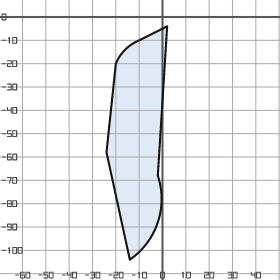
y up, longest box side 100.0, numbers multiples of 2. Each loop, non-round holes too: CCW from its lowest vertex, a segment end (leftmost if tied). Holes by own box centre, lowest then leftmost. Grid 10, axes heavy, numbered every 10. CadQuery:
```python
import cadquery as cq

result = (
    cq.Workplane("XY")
    .moveTo(-14.0, -104.0)
    .threePointArc((-2.0, -88.0), (-2.0, -68.0))
    .lineTo(2.0, -4.0)
    .lineTo(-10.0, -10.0)
    .threePointArc((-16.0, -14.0), (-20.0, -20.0))
    .lineTo(-24.0, -58.0)
    .close()
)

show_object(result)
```